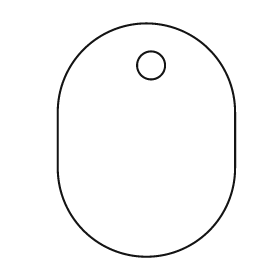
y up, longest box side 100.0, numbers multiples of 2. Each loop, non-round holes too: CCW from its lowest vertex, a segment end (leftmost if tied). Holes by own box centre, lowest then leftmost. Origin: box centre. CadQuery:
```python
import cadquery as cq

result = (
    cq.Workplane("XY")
    .moveTo(-38.0, -12.0)
    .threePointArc((0.0, -50.0), (38.0, -12.0))
    .lineTo(38.0, 12.0)
    .threePointArc((0.0, 50.0), (-38.0, 12.0))
    .close()
    .moveTo(2.0, 32.0)
    .circle(6.0)
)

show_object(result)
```